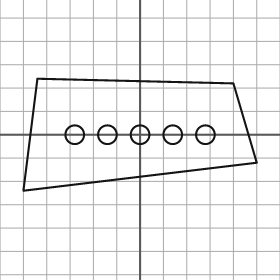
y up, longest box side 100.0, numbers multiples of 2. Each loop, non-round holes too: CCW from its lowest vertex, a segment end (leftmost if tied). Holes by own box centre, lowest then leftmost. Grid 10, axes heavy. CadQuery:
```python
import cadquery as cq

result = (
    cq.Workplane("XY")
    .moveTo(-50.0, -24.0)
    .lineTo(50.0, -12.0)
    .lineTo(40.0, 22.0)
    .lineTo(-44.0, 24.0)
    .close()
    .moveTo(-28.0, 0.0)
    .circle(4.0)
    .moveTo(-14.0, 0.0)
    .circle(4.0)
    .moveTo(0.0, 0.0)
    .circle(4.0)
    .moveTo(14.0, 0.0)
    .circle(4.0)
    .moveTo(28.0, 0.0)
    .circle(4.0)
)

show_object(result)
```